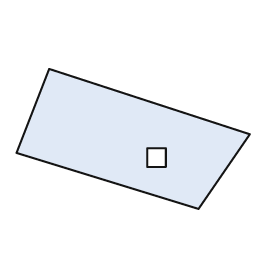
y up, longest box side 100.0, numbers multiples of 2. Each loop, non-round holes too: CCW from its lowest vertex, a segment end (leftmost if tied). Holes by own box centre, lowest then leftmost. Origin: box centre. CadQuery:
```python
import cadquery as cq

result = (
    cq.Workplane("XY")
    .moveTo(28.0, -30.0)
    .lineTo(50.0, 2.0)
    .lineTo(-36.0, 30.0)
    .lineTo(-50.0, -6.0)
    .close()
    .moveTo(6.0, -12.0)
    .lineTo(14.0, -12.0)
    .lineTo(14.0, -4.0)
    .lineTo(6.0, -4.0)
    .close()
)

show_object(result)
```